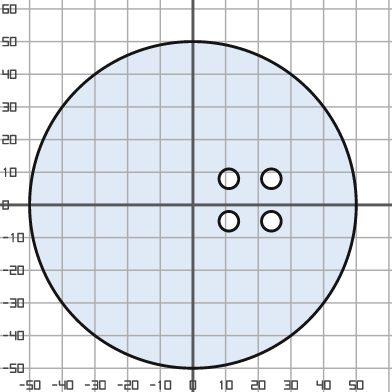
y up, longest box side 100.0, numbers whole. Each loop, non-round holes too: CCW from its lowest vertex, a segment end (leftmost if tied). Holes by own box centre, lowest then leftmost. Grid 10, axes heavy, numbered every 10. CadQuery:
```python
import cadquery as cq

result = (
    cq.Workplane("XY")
    .moveTo(0.0, 0.0)
    .circle(50.0)
    .moveTo(11.0, -5.0)
    .circle(3.0)
    .moveTo(24.0, -5.0)
    .circle(3.0)
    .moveTo(11.0, 8.0)
    .circle(3.0)
    .moveTo(24.0, 8.0)
    .circle(3.0)
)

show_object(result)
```